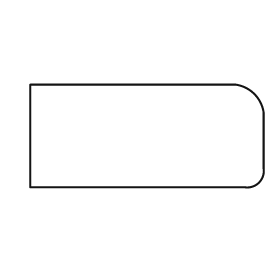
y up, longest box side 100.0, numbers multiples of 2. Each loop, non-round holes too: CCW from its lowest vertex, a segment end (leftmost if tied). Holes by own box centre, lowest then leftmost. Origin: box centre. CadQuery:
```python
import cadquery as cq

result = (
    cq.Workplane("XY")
    .moveTo(-50.0, -22.0)
    .lineTo(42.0, -22.0)
    .threePointArc((48.0, -20.0), (50.0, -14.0))
    .lineTo(50.0, 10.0)
    .threePointArc((46.0, 18.0), (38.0, 22.0))
    .lineTo(-50.0, 22.0)
    .close()
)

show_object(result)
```